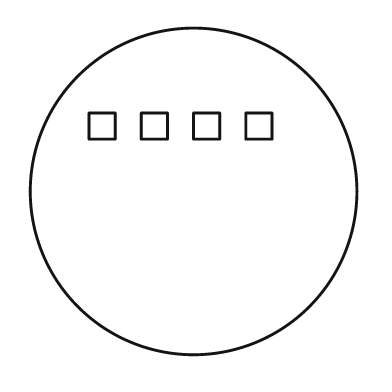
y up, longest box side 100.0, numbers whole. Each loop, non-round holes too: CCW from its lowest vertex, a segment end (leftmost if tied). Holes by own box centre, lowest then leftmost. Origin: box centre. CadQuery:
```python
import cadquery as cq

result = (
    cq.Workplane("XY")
    .moveTo(0.0, 0.0)
    .circle(50.0)
    .moveTo(-32.0, 16.0)
    .lineTo(-24.0, 16.0)
    .lineTo(-24.0, 24.0)
    .lineTo(-32.0, 24.0)
    .close()
    .moveTo(-16.0, 16.0)
    .lineTo(-8.0, 16.0)
    .lineTo(-8.0, 24.0)
    .lineTo(-16.0, 24.0)
    .close()
    .moveTo(0.0, 16.0)
    .lineTo(8.0, 16.0)
    .lineTo(8.0, 24.0)
    .lineTo(0.0, 24.0)
    .close()
    .moveTo(16.0, 16.0)
    .lineTo(24.0, 16.0)
    .lineTo(24.0, 24.0)
    .lineTo(16.0, 24.0)
    .close()
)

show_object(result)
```